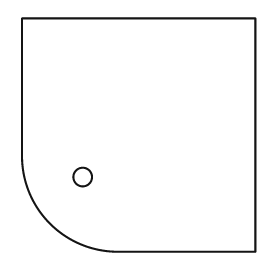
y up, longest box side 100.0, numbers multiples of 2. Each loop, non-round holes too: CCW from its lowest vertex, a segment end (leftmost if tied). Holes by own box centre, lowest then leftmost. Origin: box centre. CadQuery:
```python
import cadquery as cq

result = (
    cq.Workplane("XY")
    .moveTo(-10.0, -50.0)
    .lineTo(50.0, -50.0)
    .lineTo(50.0, 50.0)
    .lineTo(-50.0, 50.0)
    .lineTo(-50.0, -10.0)
    .threePointArc((-38.0, -38.0), (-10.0, -50.0))
    .close()
    .moveTo(-24.0, -18.0)
    .circle(4.0)
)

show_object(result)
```